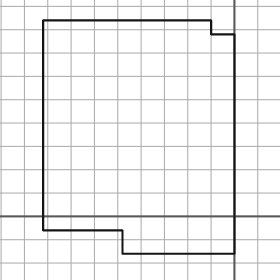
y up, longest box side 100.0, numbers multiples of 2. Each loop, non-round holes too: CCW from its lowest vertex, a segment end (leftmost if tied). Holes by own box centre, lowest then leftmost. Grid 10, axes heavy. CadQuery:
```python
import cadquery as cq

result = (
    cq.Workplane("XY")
    .moveTo(-48.0, -16.0)
    .lineTo(0.0, -16.0)
    .lineTo(0.0, 78.0)
    .lineTo(-10.0, 78.0)
    .lineTo(-10.0, 84.0)
    .lineTo(-82.0, 84.0)
    .lineTo(-82.0, -6.0)
    .lineTo(-48.0, -6.0)
    .close()
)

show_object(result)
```